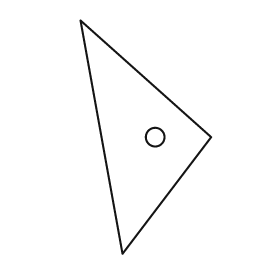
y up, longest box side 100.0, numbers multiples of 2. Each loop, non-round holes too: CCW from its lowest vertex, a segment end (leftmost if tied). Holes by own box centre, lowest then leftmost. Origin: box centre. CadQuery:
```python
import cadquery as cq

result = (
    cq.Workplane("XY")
    .moveTo(-10.0, -50.0)
    .lineTo(28.0, 0.0)
    .lineTo(-28.0, 50.0)
    .close()
    .moveTo(4.0, 0.0)
    .circle(4.0)
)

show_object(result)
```